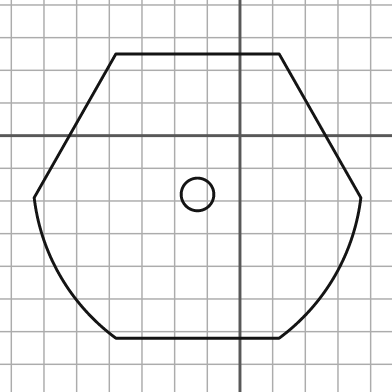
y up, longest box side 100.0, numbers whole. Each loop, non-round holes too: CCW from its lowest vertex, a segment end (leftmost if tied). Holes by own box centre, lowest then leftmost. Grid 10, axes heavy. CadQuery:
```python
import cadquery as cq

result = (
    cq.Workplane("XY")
    .moveTo(-38.0, -62.0)
    .lineTo(12.0, -62.0)
    .threePointArc((29.0, -43.0), (37.0, -19.0))
    .lineTo(12.0, 25.0)
    .lineTo(-38.0, 25.0)
    .lineTo(-63.0, -19.0)
    .threePointArc((-55.0, -43.0), (-38.0, -62.0))
    .close()
    .moveTo(-13.0, -18.0)
    .circle(5.0)
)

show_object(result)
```